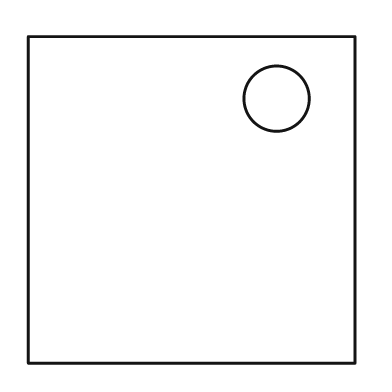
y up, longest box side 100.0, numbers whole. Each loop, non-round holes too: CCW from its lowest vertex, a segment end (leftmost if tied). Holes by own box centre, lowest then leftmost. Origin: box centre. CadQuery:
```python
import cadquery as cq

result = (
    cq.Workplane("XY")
    .moveTo(-50.0, -50.0)
    .lineTo(50.0, -50.0)
    .lineTo(50.0, 50.0)
    .lineTo(-50.0, 50.0)
    .close()
    .moveTo(26.0, 31.0)
    .circle(10.0)
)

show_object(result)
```